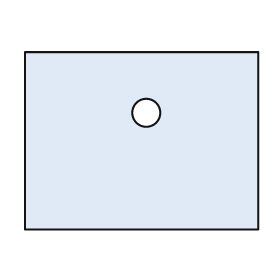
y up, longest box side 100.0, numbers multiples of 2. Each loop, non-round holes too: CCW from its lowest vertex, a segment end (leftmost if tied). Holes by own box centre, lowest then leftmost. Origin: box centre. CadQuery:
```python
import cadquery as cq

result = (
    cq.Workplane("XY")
    .moveTo(-50.0, -38.0)
    .lineTo(50.0, -38.0)
    .lineTo(50.0, 38.0)
    .lineTo(-50.0, 38.0)
    .close()
    .moveTo(2.0, 12.0)
    .circle(6.0)
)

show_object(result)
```